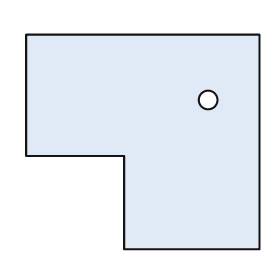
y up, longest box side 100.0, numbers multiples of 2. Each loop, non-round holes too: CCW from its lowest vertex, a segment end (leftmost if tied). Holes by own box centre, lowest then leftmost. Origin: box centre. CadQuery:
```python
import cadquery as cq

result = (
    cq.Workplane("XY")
    .moveTo(-8.0, -46.0)
    .lineTo(50.0, -46.0)
    .lineTo(50.0, 46.0)
    .lineTo(-50.0, 46.0)
    .lineTo(-50.0, -6.0)
    .lineTo(-8.0, -6.0)
    .close()
    .moveTo(28.0, 18.0)
    .circle(4.0)
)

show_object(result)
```